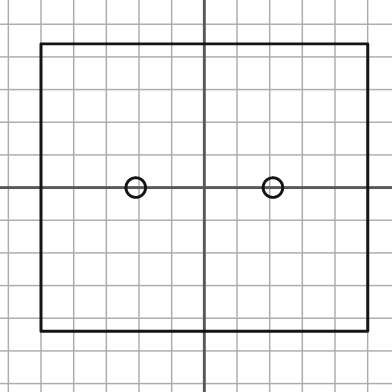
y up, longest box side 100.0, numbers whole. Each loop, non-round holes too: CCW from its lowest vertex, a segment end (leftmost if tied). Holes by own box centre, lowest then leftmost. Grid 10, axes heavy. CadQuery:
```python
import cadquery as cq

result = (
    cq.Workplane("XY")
    .moveTo(-50.0, -44.0)
    .lineTo(50.0, -44.0)
    .lineTo(50.0, 44.0)
    .lineTo(-50.0, 44.0)
    .close()
    .moveTo(-21.0, 0.0)
    .circle(3.0)
    .moveTo(21.0, 0.0)
    .circle(3.0)
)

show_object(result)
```